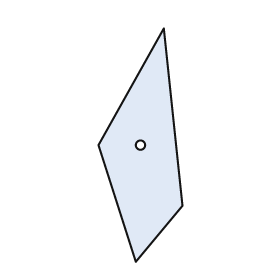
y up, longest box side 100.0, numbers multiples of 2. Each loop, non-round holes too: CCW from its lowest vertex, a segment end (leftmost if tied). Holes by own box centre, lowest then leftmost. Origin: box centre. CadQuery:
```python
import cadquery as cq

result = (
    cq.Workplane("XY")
    .moveTo(-2.0, -50.0)
    .lineTo(18.0, -26.0)
    .lineTo(10.0, 50.0)
    .lineTo(-18.0, 0.0)
    .close()
    .moveTo(0.0, 0.0)
    .circle(2.0)
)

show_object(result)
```